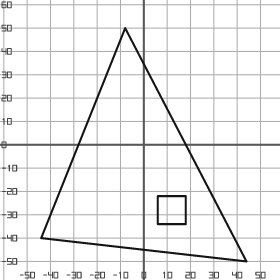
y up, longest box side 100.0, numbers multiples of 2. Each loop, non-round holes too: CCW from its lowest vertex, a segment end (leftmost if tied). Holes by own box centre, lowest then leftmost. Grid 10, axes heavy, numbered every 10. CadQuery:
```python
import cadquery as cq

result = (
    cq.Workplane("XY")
    .moveTo(44.0, -50.0)
    .lineTo(-8.0, 50.0)
    .lineTo(-44.0, -40.0)
    .close()
    .moveTo(6.0, -34.0)
    .lineTo(18.0, -34.0)
    .lineTo(18.0, -22.0)
    .lineTo(6.0, -22.0)
    .close()
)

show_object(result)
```